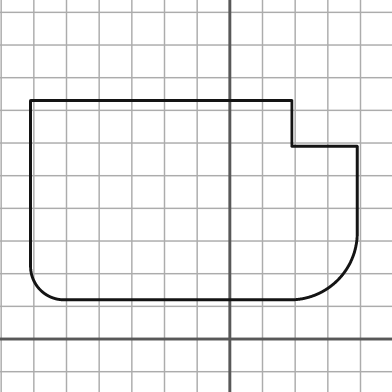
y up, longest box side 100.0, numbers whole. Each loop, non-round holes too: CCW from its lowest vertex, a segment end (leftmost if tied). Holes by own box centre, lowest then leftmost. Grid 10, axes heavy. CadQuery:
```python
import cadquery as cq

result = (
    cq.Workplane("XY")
    .moveTo(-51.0, 12.0)
    .lineTo(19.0, 12.0)
    .threePointArc((33.0, 18.0), (39.0, 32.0))
    .lineTo(39.0, 59.0)
    .lineTo(19.0, 59.0)
    .lineTo(19.0, 73.0)
    .lineTo(-61.0, 73.0)
    .lineTo(-61.0, 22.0)
    .threePointArc((-58.0, 15.0), (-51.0, 12.0))
    .close()
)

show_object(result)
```